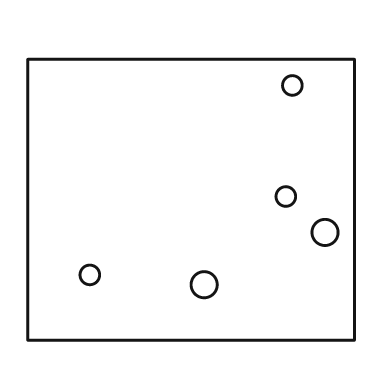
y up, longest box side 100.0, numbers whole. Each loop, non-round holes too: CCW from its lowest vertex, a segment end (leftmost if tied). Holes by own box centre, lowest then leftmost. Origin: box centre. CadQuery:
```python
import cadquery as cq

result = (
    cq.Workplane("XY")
    .moveTo(-50.0, -43.0)
    .lineTo(50.0, -43.0)
    .lineTo(50.0, 43.0)
    .lineTo(-50.0, 43.0)
    .close()
    .moveTo(4.0, -26.0)
    .circle(4.0)
    .moveTo(-31.0, -23.0)
    .circle(3.0)
    .moveTo(41.0, -10.0)
    .circle(4.0)
    .moveTo(29.0, 1.0)
    .circle(3.0)
    .moveTo(31.0, 35.0)
    .circle(3.0)
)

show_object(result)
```